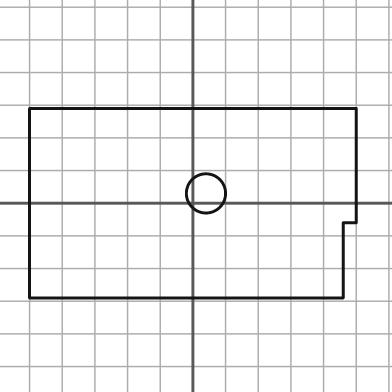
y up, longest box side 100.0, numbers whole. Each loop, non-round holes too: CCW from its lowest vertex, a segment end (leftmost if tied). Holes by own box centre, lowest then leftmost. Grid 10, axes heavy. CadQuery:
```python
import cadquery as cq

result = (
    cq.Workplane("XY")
    .moveTo(-50.0, -29.0)
    .lineTo(46.0, -29.0)
    .lineTo(46.0, -6.0)
    .lineTo(50.0, -6.0)
    .lineTo(50.0, 29.0)
    .lineTo(-50.0, 29.0)
    .close()
    .moveTo(4.0, 3.0)
    .circle(6.0)
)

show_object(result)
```